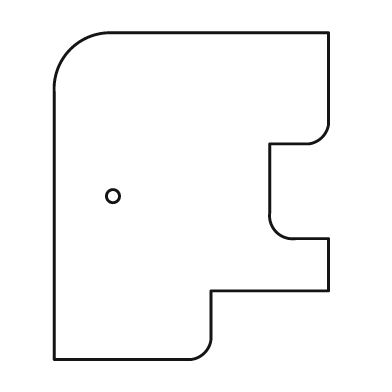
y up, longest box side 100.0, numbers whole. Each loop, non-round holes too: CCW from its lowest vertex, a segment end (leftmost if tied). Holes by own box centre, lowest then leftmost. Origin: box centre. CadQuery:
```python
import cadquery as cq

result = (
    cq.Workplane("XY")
    .moveTo(-42.0, -50.0)
    .lineTo(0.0, -50.0)
    .threePointArc((4.0, -48.0), (6.0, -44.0))
    .lineTo(6.0, -29.0)
    .lineTo(42.0, -29.0)
    .lineTo(42.0, -13.0)
    .lineTo(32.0, -13.0)
    .threePointArc((26.0, -11.0), (24.0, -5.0))
    .lineTo(24.0, 16.0)
    .lineTo(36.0, 16.0)
    .threePointArc((40.0, 18.0), (42.0, 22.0))
    .lineTo(42.0, 50.0)
    .lineTo(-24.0, 50.0)
    .threePointArc((-37.0, 45.0), (-42.0, 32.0))
    .close()
    .moveTo(-24.0, 0.0)
    .circle(2.0)
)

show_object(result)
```